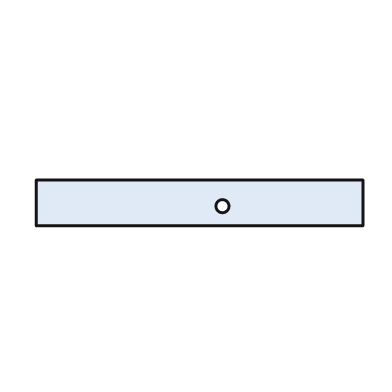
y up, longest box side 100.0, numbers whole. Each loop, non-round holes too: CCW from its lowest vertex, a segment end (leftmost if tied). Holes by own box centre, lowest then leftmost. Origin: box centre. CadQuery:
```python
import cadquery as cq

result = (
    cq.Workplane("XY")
    .moveTo(-50.0, -7.0)
    .lineTo(50.0, -7.0)
    .lineTo(50.0, 7.0)
    .lineTo(-50.0, 7.0)
    .close()
    .moveTo(7.0, -1.0)
    .circle(2.0)
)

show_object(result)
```